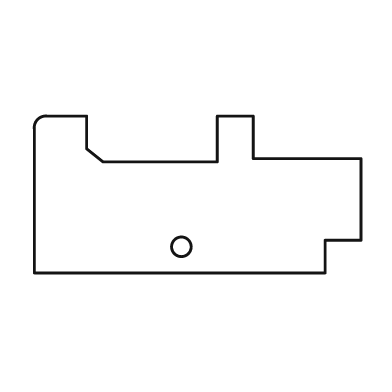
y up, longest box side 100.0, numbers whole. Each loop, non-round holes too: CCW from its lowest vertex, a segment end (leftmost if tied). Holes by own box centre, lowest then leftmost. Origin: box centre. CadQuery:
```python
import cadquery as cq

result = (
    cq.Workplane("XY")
    .moveTo(-50.0, -24.0)
    .lineTo(39.0, -24.0)
    .lineTo(39.0, -14.0)
    .lineTo(50.0, -14.0)
    .lineTo(50.0, 11.0)
    .lineTo(17.0, 11.0)
    .lineTo(17.0, 24.0)
    .lineTo(6.0, 24.0)
    .lineTo(6.0, 10.0)
    .lineTo(-29.0, 10.0)
    .lineTo(-34.0, 14.0)
    .lineTo(-34.0, 24.0)
    .lineTo(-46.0, 24.0)
    .threePointArc((-49.0, 23.0), (-50.0, 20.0))
    .close()
    .moveTo(-5.0, -16.0)
    .circle(3.0)
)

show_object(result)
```